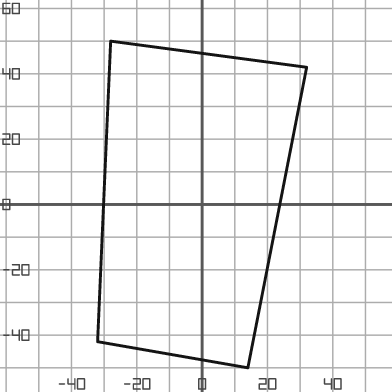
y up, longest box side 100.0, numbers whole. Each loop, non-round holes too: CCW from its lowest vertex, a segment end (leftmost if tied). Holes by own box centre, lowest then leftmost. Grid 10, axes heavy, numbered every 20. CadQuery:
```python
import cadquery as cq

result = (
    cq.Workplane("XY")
    .moveTo(14.0, -50.0)
    .lineTo(32.0, 42.0)
    .lineTo(-28.0, 50.0)
    .lineTo(-32.0, -42.0)
    .close()
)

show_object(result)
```